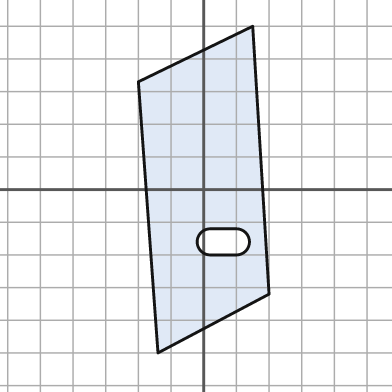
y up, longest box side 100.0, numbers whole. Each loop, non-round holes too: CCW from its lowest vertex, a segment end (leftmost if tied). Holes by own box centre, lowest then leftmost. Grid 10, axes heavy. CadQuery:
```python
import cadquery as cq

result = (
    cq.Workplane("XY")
    .moveTo(-14.0, -50.0)
    .lineTo(20.0, -32.0)
    .lineTo(15.0, 50.0)
    .lineTo(-20.0, 33.0)
    .close()
    .moveTo(2.0, -20.0)
    .lineTo(10.0, -20.0)
    .threePointArc((14.0, -16.0), (10.0, -12.0))
    .lineTo(2.0, -12.0)
    .threePointArc((-2.0, -16.0), (2.0, -20.0))
    .close()
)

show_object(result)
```